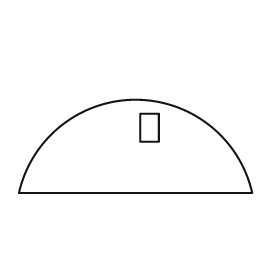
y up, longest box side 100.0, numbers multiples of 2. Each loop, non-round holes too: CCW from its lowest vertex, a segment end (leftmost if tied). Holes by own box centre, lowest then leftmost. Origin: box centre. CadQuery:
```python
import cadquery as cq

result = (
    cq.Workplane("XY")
    .moveTo(-50.0, -20.0)
    .lineTo(50.0, -20.0)
    .threePointArc((0.0, 20.0), (-50.0, -20.0))
    .close()
    .moveTo(2.0, 2.0)
    .lineTo(10.0, 2.0)
    .lineTo(10.0, 14.0)
    .lineTo(2.0, 14.0)
    .close()
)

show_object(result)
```